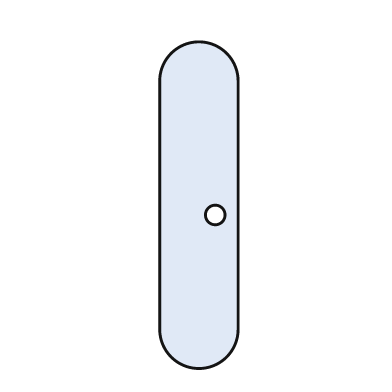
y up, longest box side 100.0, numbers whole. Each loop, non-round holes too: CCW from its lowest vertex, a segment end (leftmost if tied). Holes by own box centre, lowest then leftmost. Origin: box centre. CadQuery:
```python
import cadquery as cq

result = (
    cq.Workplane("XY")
    .moveTo(-12.0, -38.0)
    .threePointArc((0.0, -50.0), (12.0, -38.0))
    .lineTo(12.0, 38.0)
    .threePointArc((0.0, 50.0), (-12.0, 38.0))
    .close()
    .moveTo(5.0, -3.0)
    .circle(3.0)
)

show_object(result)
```